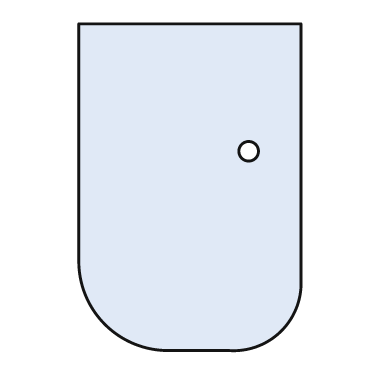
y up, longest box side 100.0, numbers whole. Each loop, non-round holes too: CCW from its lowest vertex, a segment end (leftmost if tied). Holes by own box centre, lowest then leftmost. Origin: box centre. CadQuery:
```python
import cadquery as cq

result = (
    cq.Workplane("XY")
    .moveTo(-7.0, -50.0)
    .lineTo(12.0, -50.0)
    .threePointArc((28.0, -44.0), (34.0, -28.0))
    .lineTo(34.0, 50.0)
    .lineTo(-34.0, 50.0)
    .lineTo(-34.0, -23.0)
    .threePointArc((-26.0, -42.0), (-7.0, -50.0))
    .close()
    .moveTo(18.0, 11.0)
    .circle(3.0)
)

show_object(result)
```